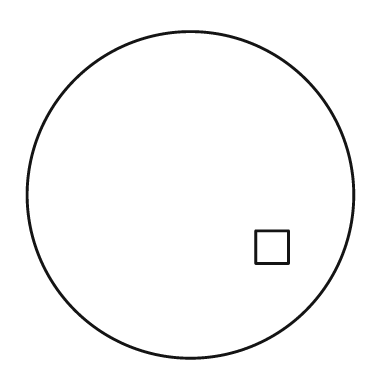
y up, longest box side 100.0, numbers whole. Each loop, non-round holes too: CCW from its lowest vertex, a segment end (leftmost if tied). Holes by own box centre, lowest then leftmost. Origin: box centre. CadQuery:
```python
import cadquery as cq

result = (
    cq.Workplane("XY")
    .moveTo(0.0, 0.0)
    .circle(50.0)
    .moveTo(20.0, -21.0)
    .lineTo(30.0, -21.0)
    .lineTo(30.0, -11.0)
    .lineTo(20.0, -11.0)
    .close()
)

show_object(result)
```